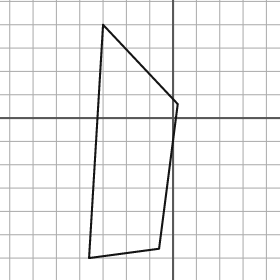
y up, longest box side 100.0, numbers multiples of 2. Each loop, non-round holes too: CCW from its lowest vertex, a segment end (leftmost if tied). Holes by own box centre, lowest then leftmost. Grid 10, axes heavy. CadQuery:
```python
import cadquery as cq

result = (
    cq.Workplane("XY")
    .moveTo(-36.0, -60.0)
    .lineTo(-6.0, -56.0)
    .lineTo(2.0, 6.0)
    .lineTo(-30.0, 40.0)
    .close()
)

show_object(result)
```